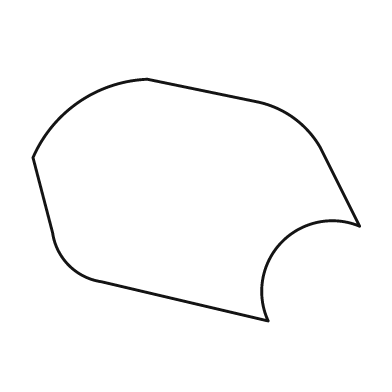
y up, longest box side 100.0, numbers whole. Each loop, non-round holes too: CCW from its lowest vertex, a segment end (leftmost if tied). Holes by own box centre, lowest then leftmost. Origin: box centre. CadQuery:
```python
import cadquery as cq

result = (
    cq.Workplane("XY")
    .moveTo(22.0, -37.0)
    .threePointArc((26.0, -13.0), (50.0, -8.0))
    .lineTo(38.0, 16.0)
    .threePointArc((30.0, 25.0), (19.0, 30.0))
    .lineTo(-15.0, 37.0)
    .threePointArc((-36.0, 30.0), (-50.0, 13.0))
    .lineTo(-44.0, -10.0)
    .threePointArc((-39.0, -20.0), (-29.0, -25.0))
    .close()
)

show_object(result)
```